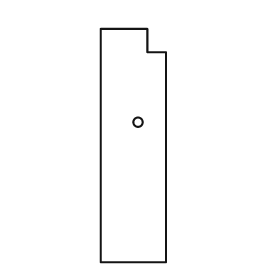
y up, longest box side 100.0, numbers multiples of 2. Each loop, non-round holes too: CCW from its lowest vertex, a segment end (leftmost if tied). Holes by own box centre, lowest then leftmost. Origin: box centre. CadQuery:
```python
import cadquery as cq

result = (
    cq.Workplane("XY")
    .moveTo(-14.0, -50.0)
    .lineTo(14.0, -50.0)
    .lineTo(14.0, 40.0)
    .lineTo(6.0, 40.0)
    .lineTo(6.0, 50.0)
    .lineTo(-14.0, 50.0)
    .close()
    .moveTo(2.0, 10.0)
    .circle(2.0)
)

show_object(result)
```